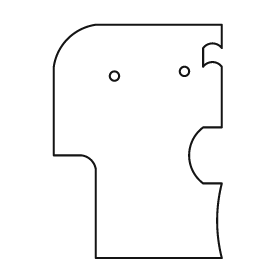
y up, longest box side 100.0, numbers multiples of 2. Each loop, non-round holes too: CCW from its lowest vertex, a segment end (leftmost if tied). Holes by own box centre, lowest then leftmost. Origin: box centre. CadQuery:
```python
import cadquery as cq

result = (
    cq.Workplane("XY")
    .moveTo(-18.0, -50.0)
    .lineTo(36.0, -50.0)
    .threePointArc((34.0, -34.0), (36.0, -18.0))
    .lineTo(28.0, -18.0)
    .threePointArc((22.0, -6.0), (28.0, 6.0))
    .lineTo(36.0, 6.0)
    .lineTo(36.0, 32.0)
    .threePointArc((32.0, 34.0), (28.0, 32.0))
    .lineTo(28.0, 40.0)
    .threePointArc((32.0, 42.0), (36.0, 40.0))
    .lineTo(36.0, 50.0)
    .lineTo(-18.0, 50.0)
    .threePointArc((-30.0, 44.0), (-36.0, 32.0))
    .lineTo(-36.0, -6.0)
    .lineTo(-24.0, -6.0)
    .threePointArc((-20.0, -8.0), (-18.0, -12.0))
    .close()
    .moveTo(-10.0, 28.0)
    .circle(2.0)
    .moveTo(20.0, 30.0)
    .circle(2.0)
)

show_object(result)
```